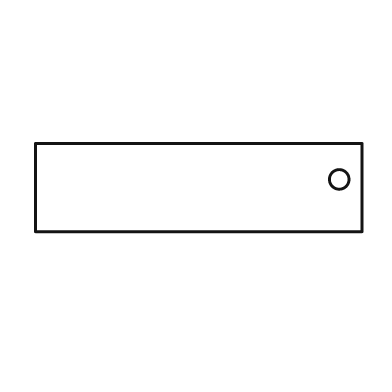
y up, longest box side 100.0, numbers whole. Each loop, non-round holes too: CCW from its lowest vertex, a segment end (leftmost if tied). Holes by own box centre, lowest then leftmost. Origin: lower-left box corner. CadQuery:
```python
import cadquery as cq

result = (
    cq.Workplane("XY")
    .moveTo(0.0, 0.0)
    .lineTo(100.0, 0.0)
    .lineTo(100.0, 27.0)
    .lineTo(0.0, 27.0)
    .close()
    .moveTo(93.0, 16.0)
    .circle(3.0)
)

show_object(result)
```